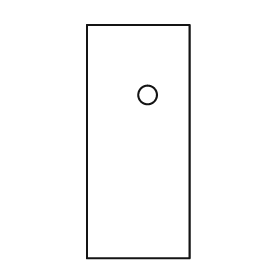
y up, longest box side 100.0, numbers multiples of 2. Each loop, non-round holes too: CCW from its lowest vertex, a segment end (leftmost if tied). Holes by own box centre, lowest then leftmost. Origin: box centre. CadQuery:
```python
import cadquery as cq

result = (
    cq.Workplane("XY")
    .moveTo(-22.0, -50.0)
    .lineTo(22.0, -50.0)
    .lineTo(22.0, 50.0)
    .lineTo(-22.0, 50.0)
    .close()
    .moveTo(4.0, 20.0)
    .circle(4.0)
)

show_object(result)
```